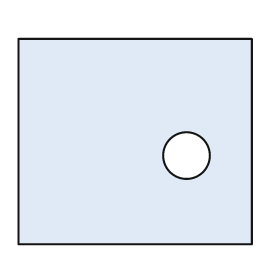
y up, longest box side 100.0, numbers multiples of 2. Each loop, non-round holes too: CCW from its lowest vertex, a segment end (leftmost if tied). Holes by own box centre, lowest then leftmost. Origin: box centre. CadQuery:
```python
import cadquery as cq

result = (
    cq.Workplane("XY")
    .moveTo(-50.0, -44.0)
    .lineTo(50.0, -44.0)
    .lineTo(50.0, 44.0)
    .lineTo(-50.0, 44.0)
    .close()
    .moveTo(22.0, -6.0)
    .circle(10.0)
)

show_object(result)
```